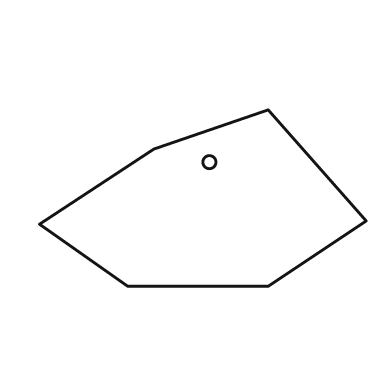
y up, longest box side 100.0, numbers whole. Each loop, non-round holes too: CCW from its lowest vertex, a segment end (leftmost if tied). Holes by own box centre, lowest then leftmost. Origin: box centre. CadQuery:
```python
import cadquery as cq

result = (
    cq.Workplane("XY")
    .moveTo(-23.0, -27.0)
    .lineTo(20.0, -27.0)
    .lineTo(50.0, -7.0)
    .lineTo(20.0, 27.0)
    .lineTo(-15.0, 15.0)
    .lineTo(-50.0, -8.0)
    .close()
    .moveTo(2.0, 11.0)
    .circle(2.0)
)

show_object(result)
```